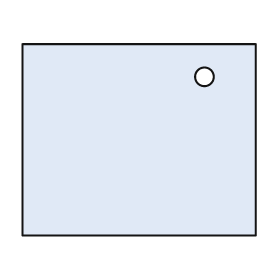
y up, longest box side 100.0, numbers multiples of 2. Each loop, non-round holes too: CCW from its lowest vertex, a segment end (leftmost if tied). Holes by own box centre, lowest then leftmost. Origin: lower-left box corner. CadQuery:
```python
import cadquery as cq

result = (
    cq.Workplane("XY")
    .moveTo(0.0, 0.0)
    .lineTo(100.0, 0.0)
    .lineTo(100.0, 82.0)
    .lineTo(0.0, 82.0)
    .close()
    .moveTo(78.0, 68.0)
    .circle(4.0)
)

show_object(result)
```